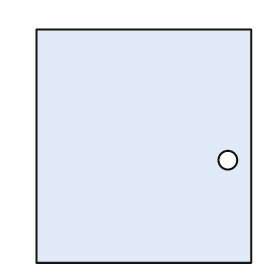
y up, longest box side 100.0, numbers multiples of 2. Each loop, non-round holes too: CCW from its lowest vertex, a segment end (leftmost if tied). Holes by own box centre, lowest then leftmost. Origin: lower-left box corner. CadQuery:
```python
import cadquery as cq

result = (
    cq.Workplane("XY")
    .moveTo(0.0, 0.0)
    .lineTo(92.0, 0.0)
    .lineTo(92.0, 100.0)
    .lineTo(0.0, 100.0)
    .close()
    .moveTo(82.0, 44.0)
    .circle(4.0)
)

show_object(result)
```